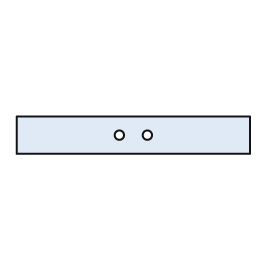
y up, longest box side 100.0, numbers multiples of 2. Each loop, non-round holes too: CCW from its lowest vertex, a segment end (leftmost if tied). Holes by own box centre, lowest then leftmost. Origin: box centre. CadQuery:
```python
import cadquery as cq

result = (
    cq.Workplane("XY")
    .moveTo(-50.0, -8.0)
    .lineTo(50.0, -8.0)
    .lineTo(50.0, 8.0)
    .lineTo(-50.0, 8.0)
    .close()
    .moveTo(-6.0, 0.0)
    .circle(2.0)
    .moveTo(6.0, 0.0)
    .circle(2.0)
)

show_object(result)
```